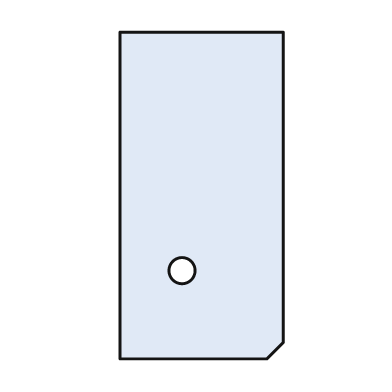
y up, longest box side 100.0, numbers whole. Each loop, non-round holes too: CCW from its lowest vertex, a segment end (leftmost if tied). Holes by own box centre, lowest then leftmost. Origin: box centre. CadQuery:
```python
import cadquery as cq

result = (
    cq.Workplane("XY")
    .moveTo(-25.0, -50.0)
    .lineTo(20.0, -50.0)
    .lineTo(25.0, -45.0)
    .lineTo(25.0, 50.0)
    .lineTo(-25.0, 50.0)
    .close()
    .moveTo(-6.0, -23.0)
    .circle(4.0)
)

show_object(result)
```